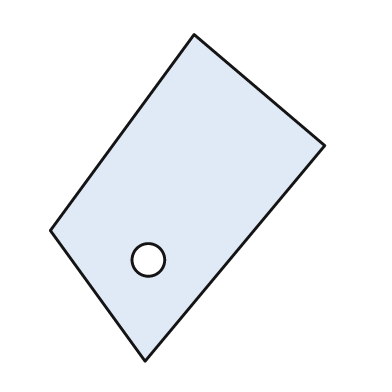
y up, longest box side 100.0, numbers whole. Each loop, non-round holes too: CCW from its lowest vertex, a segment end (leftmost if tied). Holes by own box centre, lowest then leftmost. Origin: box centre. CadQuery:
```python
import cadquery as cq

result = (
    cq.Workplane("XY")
    .moveTo(-13.0, -50.0)
    .lineTo(42.0, 16.0)
    .lineTo(2.0, 50.0)
    .lineTo(-42.0, -10.0)
    .close()
    .moveTo(-12.0, -19.0)
    .circle(5.0)
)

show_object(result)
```